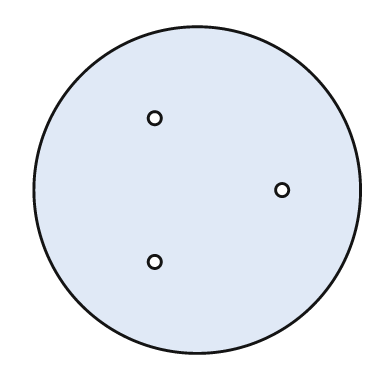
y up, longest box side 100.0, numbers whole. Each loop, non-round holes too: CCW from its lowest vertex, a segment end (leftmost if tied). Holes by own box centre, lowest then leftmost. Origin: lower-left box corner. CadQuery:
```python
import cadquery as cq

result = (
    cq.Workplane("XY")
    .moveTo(50.0, 50.0)
    .circle(50.0)
    .moveTo(37.0, 28.0)
    .circle(2.0)
    .moveTo(76.0, 50.0)
    .circle(2.0)
    .moveTo(37.0, 72.0)
    .circle(2.0)
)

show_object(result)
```